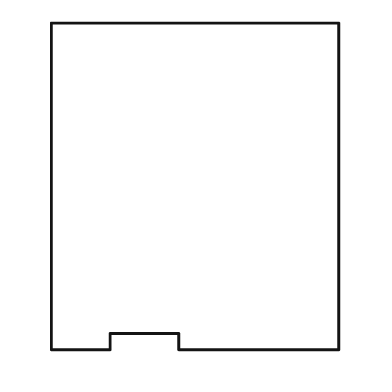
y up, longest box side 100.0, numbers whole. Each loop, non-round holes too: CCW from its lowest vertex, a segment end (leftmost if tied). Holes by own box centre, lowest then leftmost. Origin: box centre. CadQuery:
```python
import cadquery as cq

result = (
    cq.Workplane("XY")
    .moveTo(-44.0, -50.0)
    .lineTo(-26.0, -50.0)
    .lineTo(-26.0, -45.0)
    .lineTo(-5.0, -45.0)
    .lineTo(-5.0, -50.0)
    .lineTo(44.0, -50.0)
    .lineTo(44.0, 50.0)
    .lineTo(-44.0, 50.0)
    .close()
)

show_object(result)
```